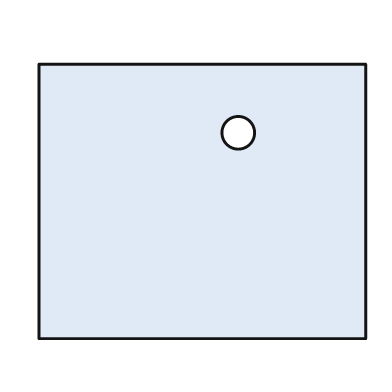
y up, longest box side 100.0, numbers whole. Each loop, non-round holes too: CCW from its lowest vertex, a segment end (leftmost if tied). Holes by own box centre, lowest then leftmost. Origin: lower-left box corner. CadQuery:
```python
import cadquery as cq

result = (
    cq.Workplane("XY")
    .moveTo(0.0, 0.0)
    .lineTo(100.0, 0.0)
    .lineTo(100.0, 84.0)
    .lineTo(0.0, 84.0)
    .close()
    .moveTo(61.0, 63.0)
    .circle(5.0)
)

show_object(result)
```